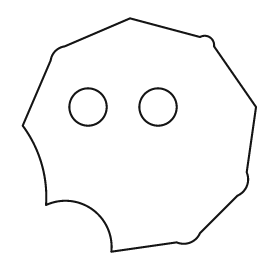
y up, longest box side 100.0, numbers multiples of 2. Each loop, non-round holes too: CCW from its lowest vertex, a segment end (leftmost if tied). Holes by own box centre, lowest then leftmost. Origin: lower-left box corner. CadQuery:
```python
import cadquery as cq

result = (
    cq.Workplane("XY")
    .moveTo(38.0, 0.0)
    .lineTo(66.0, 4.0)
    .threePointArc((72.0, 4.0), (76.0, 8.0))
    .lineTo(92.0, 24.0)
    .threePointArc((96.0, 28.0), (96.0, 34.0))
    .lineTo(100.0, 62.0)
    .lineTo(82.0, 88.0)
    .threePointArc((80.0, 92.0), (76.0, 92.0))
    .lineTo(46.0, 100.0)
    .lineTo(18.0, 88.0)
    .threePointArc((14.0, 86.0), (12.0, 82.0))
    .lineTo(0.0, 54.0)
    .threePointArc((8.0, 38.0), (10.0, 20.0))
    .threePointArc((30.0, 18.0), (38.0, 0.0))
    .close()
    .moveTo(28.0, 62.0)
    .circle(8.0)
    .moveTo(58.0, 62.0)
    .circle(8.0)
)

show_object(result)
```